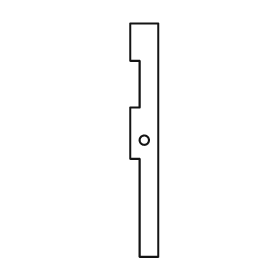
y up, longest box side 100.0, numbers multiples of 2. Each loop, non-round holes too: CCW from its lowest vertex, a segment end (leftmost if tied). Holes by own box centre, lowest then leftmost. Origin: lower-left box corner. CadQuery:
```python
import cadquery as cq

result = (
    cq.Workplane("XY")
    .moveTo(4.0, 0.0)
    .lineTo(12.0, 0.0)
    .lineTo(12.0, 100.0)
    .lineTo(0.0, 100.0)
    .lineTo(0.0, 84.0)
    .lineTo(4.0, 84.0)
    .lineTo(4.0, 64.0)
    .lineTo(0.0, 64.0)
    .lineTo(0.0, 42.0)
    .lineTo(4.0, 42.0)
    .close()
    .moveTo(6.0, 50.0)
    .circle(2.0)
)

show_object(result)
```